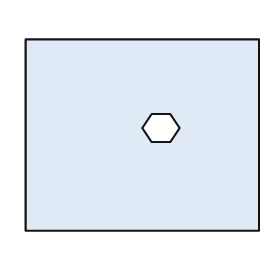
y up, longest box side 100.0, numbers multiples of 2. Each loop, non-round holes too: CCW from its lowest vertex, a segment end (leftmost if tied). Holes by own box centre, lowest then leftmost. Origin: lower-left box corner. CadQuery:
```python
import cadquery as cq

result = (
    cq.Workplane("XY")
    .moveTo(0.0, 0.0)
    .lineTo(100.0, 0.0)
    .lineTo(100.0, 82.0)
    .lineTo(0.0, 82.0)
    .close()
    .moveTo(54.0, 38.0)
    .lineTo(62.0, 38.0)
    .lineTo(66.0, 44.0)
    .lineTo(62.0, 50.0)
    .lineTo(54.0, 50.0)
    .lineTo(50.0, 44.0)
    .close()
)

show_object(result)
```